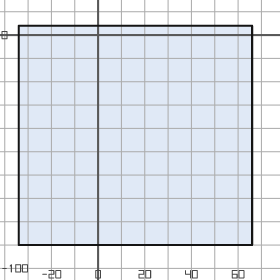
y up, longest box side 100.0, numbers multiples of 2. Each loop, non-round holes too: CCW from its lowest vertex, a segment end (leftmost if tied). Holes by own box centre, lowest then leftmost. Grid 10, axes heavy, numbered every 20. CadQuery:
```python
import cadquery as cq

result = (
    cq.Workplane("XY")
    .moveTo(-34.0, -90.0)
    .lineTo(66.0, -90.0)
    .lineTo(66.0, 4.0)
    .lineTo(-34.0, 4.0)
    .close()
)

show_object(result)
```